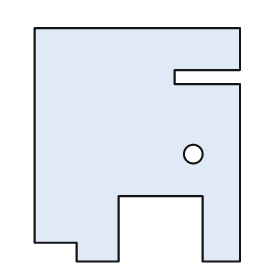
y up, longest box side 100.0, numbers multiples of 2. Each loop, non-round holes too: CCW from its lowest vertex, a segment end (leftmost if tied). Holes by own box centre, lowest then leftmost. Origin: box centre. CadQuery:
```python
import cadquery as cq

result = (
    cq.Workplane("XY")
    .moveTo(-26.0, -50.0)
    .lineTo(-8.0, -50.0)
    .lineTo(-8.0, -22.0)
    .lineTo(28.0, -22.0)
    .lineTo(28.0, -50.0)
    .lineTo(44.0, -50.0)
    .lineTo(44.0, 26.0)
    .lineTo(16.0, 26.0)
    .lineTo(16.0, 32.0)
    .lineTo(44.0, 32.0)
    .lineTo(44.0, 50.0)
    .lineTo(-44.0, 50.0)
    .lineTo(-44.0, -42.0)
    .lineTo(-26.0, -42.0)
    .close()
    .moveTo(24.0, -4.0)
    .circle(4.0)
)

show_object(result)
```